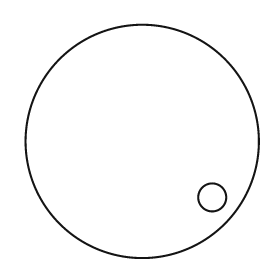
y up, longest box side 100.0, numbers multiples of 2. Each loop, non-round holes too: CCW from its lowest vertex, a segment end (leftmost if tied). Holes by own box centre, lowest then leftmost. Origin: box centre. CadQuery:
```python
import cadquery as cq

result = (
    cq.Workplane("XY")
    .moveTo(0.0, 0.0)
    .circle(50.0)
    .moveTo(30.0, -24.0)
    .circle(6.0)
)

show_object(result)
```